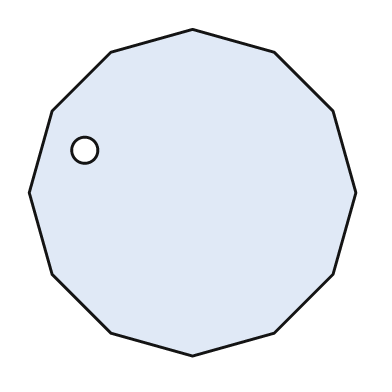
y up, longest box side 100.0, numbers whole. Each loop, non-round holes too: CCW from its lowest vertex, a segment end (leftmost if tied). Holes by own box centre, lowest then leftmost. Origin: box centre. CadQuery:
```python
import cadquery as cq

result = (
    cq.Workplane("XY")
    .moveTo(0.0, -50.0)
    .lineTo(25.0, -43.0)
    .lineTo(43.0, -25.0)
    .lineTo(50.0, 0.0)
    .lineTo(43.0, 25.0)
    .lineTo(25.0, 43.0)
    .lineTo(0.0, 50.0)
    .lineTo(-25.0, 43.0)
    .lineTo(-43.0, 25.0)
    .lineTo(-50.0, 0.0)
    .lineTo(-43.0, -25.0)
    .lineTo(-25.0, -43.0)
    .close()
    .moveTo(-33.0, 13.0)
    .circle(4.0)
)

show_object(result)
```